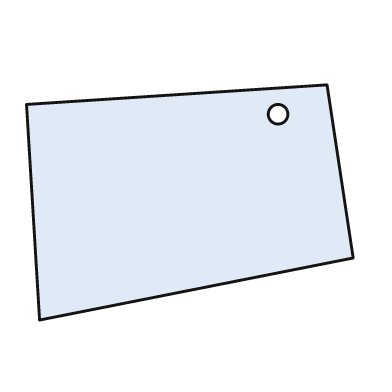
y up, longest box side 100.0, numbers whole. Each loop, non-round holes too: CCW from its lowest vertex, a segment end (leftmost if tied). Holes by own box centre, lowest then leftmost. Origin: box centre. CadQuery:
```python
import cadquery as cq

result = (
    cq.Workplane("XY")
    .moveTo(-46.0, -36.0)
    .lineTo(50.0, -17.0)
    .lineTo(42.0, 36.0)
    .lineTo(-50.0, 30.0)
    .close()
    .moveTo(27.0, 27.0)
    .circle(3.0)
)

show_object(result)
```